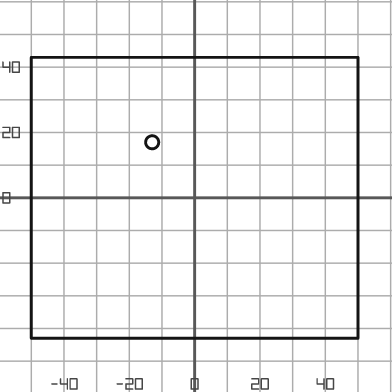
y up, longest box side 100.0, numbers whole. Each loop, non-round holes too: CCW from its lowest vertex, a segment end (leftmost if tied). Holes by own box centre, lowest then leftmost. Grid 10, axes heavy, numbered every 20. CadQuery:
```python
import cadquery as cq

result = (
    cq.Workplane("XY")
    .moveTo(-50.0, -43.0)
    .lineTo(50.0, -43.0)
    .lineTo(50.0, 43.0)
    .lineTo(-50.0, 43.0)
    .close()
    .moveTo(-13.0, 17.0)
    .circle(2.0)
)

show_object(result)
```